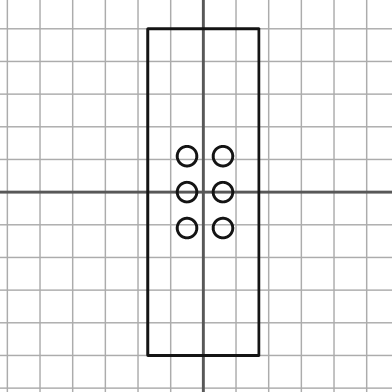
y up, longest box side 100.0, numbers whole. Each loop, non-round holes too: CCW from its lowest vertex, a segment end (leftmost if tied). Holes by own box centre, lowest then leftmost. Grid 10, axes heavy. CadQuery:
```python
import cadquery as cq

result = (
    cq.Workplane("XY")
    .moveTo(-17.0, -50.0)
    .lineTo(17.0, -50.0)
    .lineTo(17.0, 50.0)
    .lineTo(-17.0, 50.0)
    .close()
    .moveTo(-5.0, -11.0)
    .circle(3.0)
    .moveTo(6.0, -11.0)
    .circle(3.0)
    .moveTo(-5.0, 0.0)
    .circle(3.0)
    .moveTo(6.0, 0.0)
    .circle(3.0)
    .moveTo(-5.0, 11.0)
    .circle(3.0)
    .moveTo(6.0, 11.0)
    .circle(3.0)
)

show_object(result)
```